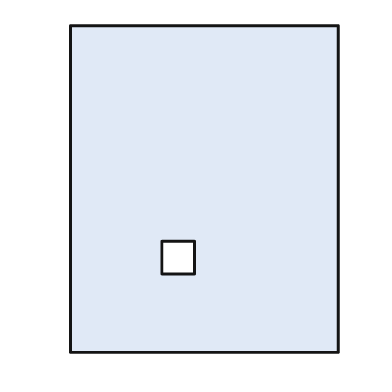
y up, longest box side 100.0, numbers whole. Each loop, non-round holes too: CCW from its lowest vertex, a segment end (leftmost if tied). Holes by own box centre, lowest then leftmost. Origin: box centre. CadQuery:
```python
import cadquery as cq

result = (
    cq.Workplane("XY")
    .moveTo(-41.0, -50.0)
    .lineTo(41.0, -50.0)
    .lineTo(41.0, 50.0)
    .lineTo(-41.0, 50.0)
    .close()
    .moveTo(-13.0, -26.0)
    .lineTo(-3.0, -26.0)
    .lineTo(-3.0, -16.0)
    .lineTo(-13.0, -16.0)
    .close()
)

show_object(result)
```